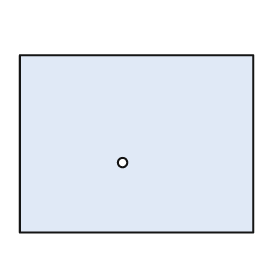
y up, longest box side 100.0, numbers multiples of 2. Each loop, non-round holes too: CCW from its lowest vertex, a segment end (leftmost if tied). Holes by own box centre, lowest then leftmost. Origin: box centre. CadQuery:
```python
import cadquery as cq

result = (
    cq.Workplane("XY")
    .moveTo(-50.0, -38.0)
    .lineTo(50.0, -38.0)
    .lineTo(50.0, 38.0)
    .lineTo(-50.0, 38.0)
    .close()
    .moveTo(-6.0, -8.0)
    .circle(2.0)
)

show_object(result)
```